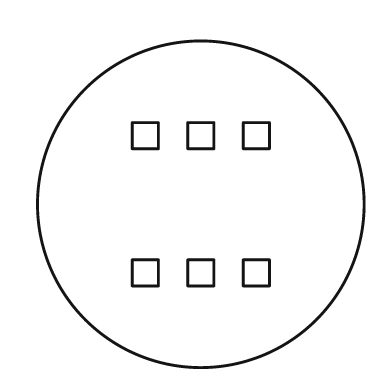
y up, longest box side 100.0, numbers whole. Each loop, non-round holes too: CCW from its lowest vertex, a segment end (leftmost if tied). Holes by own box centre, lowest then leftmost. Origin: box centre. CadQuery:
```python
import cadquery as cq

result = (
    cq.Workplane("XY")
    .moveTo(0.0, 0.0)
    .circle(50.0)
    .moveTo(-21.0, -25.0)
    .lineTo(-13.0, -25.0)
    .lineTo(-13.0, -17.0)
    .lineTo(-21.0, -17.0)
    .close()
    .moveTo(-4.0, -25.0)
    .lineTo(4.0, -25.0)
    .lineTo(4.0, -17.0)
    .lineTo(-4.0, -17.0)
    .close()
    .moveTo(13.0, -25.0)
    .lineTo(21.0, -25.0)
    .lineTo(21.0, -17.0)
    .lineTo(13.0, -17.0)
    .close()
    .moveTo(-21.0, 17.0)
    .lineTo(-13.0, 17.0)
    .lineTo(-13.0, 25.0)
    .lineTo(-21.0, 25.0)
    .close()
    .moveTo(-4.0, 17.0)
    .lineTo(4.0, 17.0)
    .lineTo(4.0, 25.0)
    .lineTo(-4.0, 25.0)
    .close()
    .moveTo(13.0, 17.0)
    .lineTo(21.0, 17.0)
    .lineTo(21.0, 25.0)
    .lineTo(13.0, 25.0)
    .close()
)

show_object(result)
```